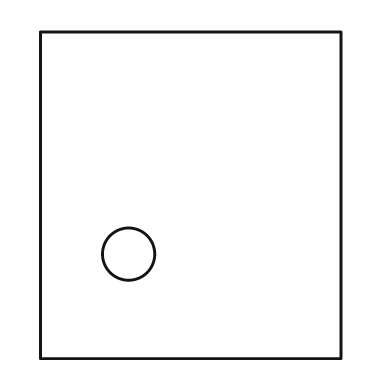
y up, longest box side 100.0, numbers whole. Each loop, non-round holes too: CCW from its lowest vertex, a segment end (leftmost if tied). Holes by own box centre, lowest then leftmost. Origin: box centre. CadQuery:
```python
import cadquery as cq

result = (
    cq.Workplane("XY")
    .moveTo(-46.0, -50.0)
    .lineTo(46.0, -50.0)
    .lineTo(46.0, 50.0)
    .lineTo(-46.0, 50.0)
    .close()
    .moveTo(-19.0, -18.0)
    .circle(8.0)
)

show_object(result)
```